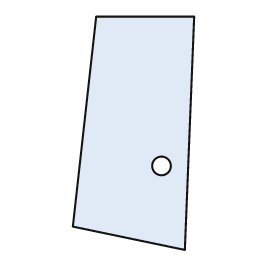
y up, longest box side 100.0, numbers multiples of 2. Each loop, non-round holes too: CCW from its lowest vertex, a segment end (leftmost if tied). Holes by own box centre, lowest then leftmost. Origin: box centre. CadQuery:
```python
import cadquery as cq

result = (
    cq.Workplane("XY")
    .moveTo(22.0, -50.0)
    .lineTo(26.0, 50.0)
    .lineTo(-16.0, 50.0)
    .lineTo(-26.0, -40.0)
    .close()
    .moveTo(12.0, -14.0)
    .circle(4.0)
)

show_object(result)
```